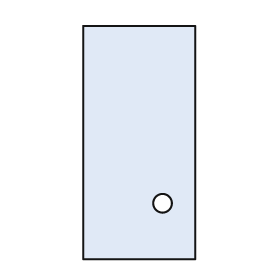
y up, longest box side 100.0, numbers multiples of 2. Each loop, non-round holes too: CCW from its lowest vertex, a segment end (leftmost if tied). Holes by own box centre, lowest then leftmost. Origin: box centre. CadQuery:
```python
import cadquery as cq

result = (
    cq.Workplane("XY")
    .moveTo(-24.0, -50.0)
    .lineTo(24.0, -50.0)
    .lineTo(24.0, 50.0)
    .lineTo(-24.0, 50.0)
    .close()
    .moveTo(10.0, -26.0)
    .circle(4.0)
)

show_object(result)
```